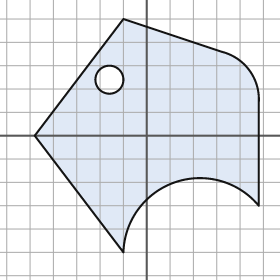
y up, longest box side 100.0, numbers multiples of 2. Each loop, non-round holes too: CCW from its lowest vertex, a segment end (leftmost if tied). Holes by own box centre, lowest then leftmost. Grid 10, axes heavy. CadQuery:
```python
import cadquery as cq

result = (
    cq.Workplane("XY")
    .moveTo(-10.0, -50.0)
    .threePointArc((12.0, -20.0), (48.0, -30.0))
    .lineTo(48.0, 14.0)
    .threePointArc((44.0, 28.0), (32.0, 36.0))
    .lineTo(-10.0, 50.0)
    .lineTo(-48.0, 0.0)
    .close()
    .moveTo(-16.0, 24.0)
    .circle(6.0)
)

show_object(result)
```